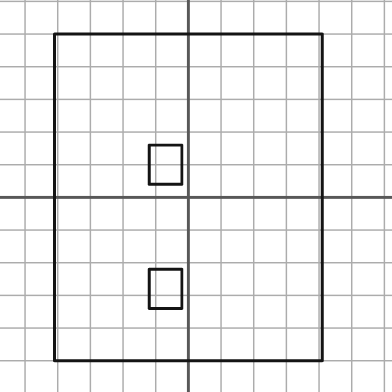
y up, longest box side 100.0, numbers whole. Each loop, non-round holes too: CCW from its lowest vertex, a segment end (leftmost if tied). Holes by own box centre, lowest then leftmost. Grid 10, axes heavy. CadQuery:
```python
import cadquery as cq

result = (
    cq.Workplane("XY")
    .moveTo(-41.0, -50.0)
    .lineTo(41.0, -50.0)
    .lineTo(41.0, 50.0)
    .lineTo(-41.0, 50.0)
    .close()
    .moveTo(-12.0, -34.0)
    .lineTo(-2.0, -34.0)
    .lineTo(-2.0, -22.0)
    .lineTo(-12.0, -22.0)
    .close()
    .moveTo(-12.0, 4.0)
    .lineTo(-2.0, 4.0)
    .lineTo(-2.0, 16.0)
    .lineTo(-12.0, 16.0)
    .close()
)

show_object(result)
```